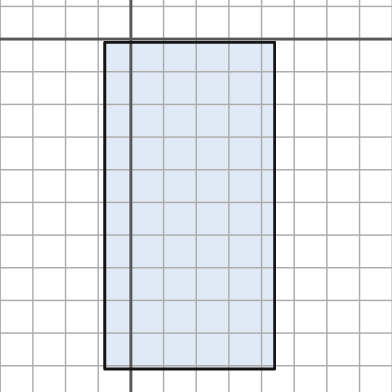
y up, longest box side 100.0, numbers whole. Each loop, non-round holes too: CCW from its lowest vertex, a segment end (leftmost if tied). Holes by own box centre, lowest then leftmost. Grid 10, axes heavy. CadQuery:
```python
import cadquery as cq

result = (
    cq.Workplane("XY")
    .moveTo(-8.0, -101.0)
    .lineTo(44.0, -101.0)
    .lineTo(44.0, -1.0)
    .lineTo(-8.0, -1.0)
    .close()
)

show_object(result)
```